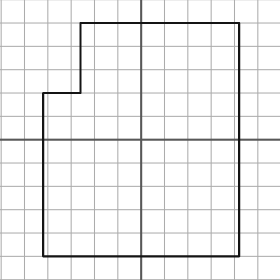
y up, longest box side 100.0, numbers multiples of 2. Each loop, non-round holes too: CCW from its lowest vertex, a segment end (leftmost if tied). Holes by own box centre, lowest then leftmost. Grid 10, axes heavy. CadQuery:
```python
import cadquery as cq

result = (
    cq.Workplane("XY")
    .moveTo(-42.0, -50.0)
    .lineTo(42.0, -50.0)
    .lineTo(42.0, 50.0)
    .lineTo(-26.0, 50.0)
    .lineTo(-26.0, 20.0)
    .lineTo(-42.0, 20.0)
    .close()
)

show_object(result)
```